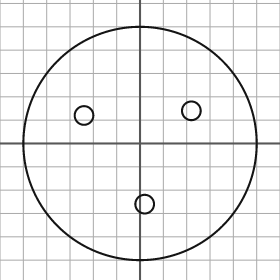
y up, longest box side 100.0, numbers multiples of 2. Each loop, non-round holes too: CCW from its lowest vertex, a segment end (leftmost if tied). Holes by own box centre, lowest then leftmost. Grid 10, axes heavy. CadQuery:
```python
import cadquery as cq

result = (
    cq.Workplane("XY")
    .moveTo(0.0, 0.0)
    .circle(50.0)
    .moveTo(2.0, -26.0)
    .circle(4.0)
    .moveTo(-24.0, 12.0)
    .circle(4.0)
    .moveTo(22.0, 14.0)
    .circle(4.0)
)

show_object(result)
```